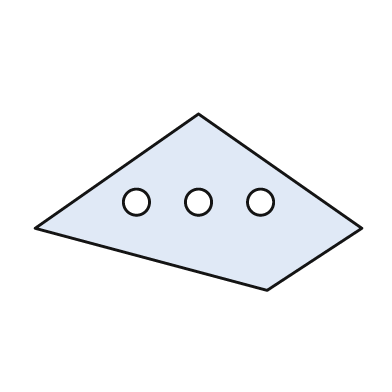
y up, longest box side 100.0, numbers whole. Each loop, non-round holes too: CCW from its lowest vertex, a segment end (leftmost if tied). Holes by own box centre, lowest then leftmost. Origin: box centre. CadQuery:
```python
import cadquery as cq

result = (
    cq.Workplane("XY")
    .moveTo(21.0, -27.0)
    .lineTo(50.0, -8.0)
    .lineTo(0.0, 27.0)
    .lineTo(-50.0, -8.0)
    .close()
    .moveTo(-19.0, 0.0)
    .circle(4.0)
    .moveTo(0.0, 0.0)
    .circle(4.0)
    .moveTo(19.0, 0.0)
    .circle(4.0)
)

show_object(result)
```